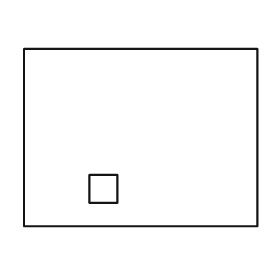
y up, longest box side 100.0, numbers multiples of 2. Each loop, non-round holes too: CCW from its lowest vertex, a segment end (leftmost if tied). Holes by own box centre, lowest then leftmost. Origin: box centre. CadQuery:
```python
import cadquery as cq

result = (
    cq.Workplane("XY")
    .moveTo(-50.0, -38.0)
    .lineTo(50.0, -38.0)
    .lineTo(50.0, 38.0)
    .lineTo(-50.0, 38.0)
    .close()
    .moveTo(-22.0, -28.0)
    .lineTo(-10.0, -28.0)
    .lineTo(-10.0, -16.0)
    .lineTo(-22.0, -16.0)
    .close()
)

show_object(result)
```